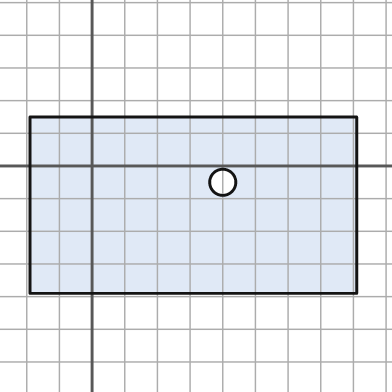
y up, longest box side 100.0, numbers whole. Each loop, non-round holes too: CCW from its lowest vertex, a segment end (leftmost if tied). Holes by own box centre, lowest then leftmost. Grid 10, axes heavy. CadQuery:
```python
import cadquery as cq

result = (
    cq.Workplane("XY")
    .moveTo(-19.0, -39.0)
    .lineTo(81.0, -39.0)
    .lineTo(81.0, 15.0)
    .lineTo(-19.0, 15.0)
    .close()
    .moveTo(40.0, -5.0)
    .circle(4.0)
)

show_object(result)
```